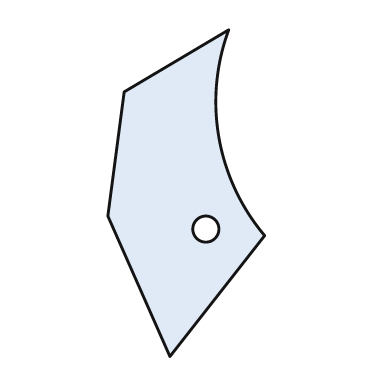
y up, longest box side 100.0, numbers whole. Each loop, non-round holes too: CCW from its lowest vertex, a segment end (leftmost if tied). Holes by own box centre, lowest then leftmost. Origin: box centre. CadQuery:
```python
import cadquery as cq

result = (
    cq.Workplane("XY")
    .moveTo(-5.0, -50.0)
    .lineTo(24.0, -13.0)
    .threePointArc((10.0, 17.0), (13.0, 50.0))
    .lineTo(-19.0, 31.0)
    .lineTo(-24.0, -7.0)
    .close()
    .moveTo(6.0, -11.0)
    .circle(4.0)
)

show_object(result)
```